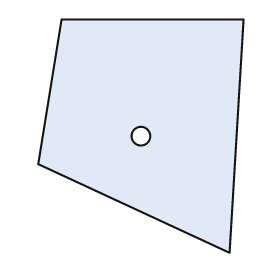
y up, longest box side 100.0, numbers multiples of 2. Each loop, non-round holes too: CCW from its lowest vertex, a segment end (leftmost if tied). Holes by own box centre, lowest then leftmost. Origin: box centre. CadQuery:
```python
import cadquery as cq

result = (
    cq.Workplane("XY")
    .moveTo(38.0, -50.0)
    .lineTo(44.0, 50.0)
    .lineTo(-34.0, 50.0)
    .lineTo(-44.0, -12.0)
    .close()
    .moveTo(0.0, 0.0)
    .circle(4.0)
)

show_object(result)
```